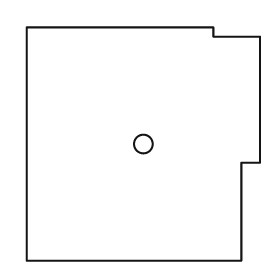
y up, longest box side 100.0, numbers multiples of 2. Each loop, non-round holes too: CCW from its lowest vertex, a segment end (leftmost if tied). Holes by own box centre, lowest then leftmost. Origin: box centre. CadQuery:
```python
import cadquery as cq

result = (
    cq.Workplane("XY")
    .moveTo(-50.0, -50.0)
    .lineTo(42.0, -50.0)
    .lineTo(42.0, -8.0)
    .lineTo(50.0, -8.0)
    .lineTo(50.0, 46.0)
    .lineTo(30.0, 46.0)
    .lineTo(30.0, 50.0)
    .lineTo(-50.0, 50.0)
    .close()
    .moveTo(0.0, 0.0)
    .circle(4.0)
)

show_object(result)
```